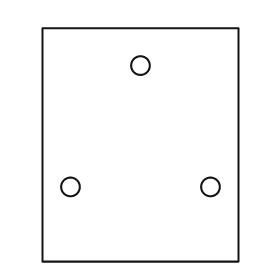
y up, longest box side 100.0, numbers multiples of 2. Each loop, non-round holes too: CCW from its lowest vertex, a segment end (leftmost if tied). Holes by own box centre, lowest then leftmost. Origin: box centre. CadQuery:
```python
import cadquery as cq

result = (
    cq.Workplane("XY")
    .moveTo(-42.0, -50.0)
    .lineTo(42.0, -50.0)
    .lineTo(42.0, 50.0)
    .lineTo(-42.0, 50.0)
    .close()
    .moveTo(-30.0, -18.0)
    .circle(4.0)
    .moveTo(30.0, -18.0)
    .circle(4.0)
    .moveTo(0.0, 34.0)
    .circle(4.0)
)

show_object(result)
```